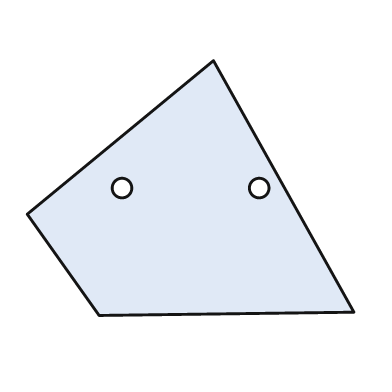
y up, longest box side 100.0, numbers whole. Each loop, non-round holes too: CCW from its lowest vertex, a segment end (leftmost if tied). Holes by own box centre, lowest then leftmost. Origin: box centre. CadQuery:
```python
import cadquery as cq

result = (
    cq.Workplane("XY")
    .moveTo(-28.0, -39.0)
    .lineTo(50.0, -38.0)
    .lineTo(7.0, 39.0)
    .lineTo(-50.0, -8.0)
    .close()
    .moveTo(-21.0, 0.0)
    .circle(3.0)
    .moveTo(21.0, 0.0)
    .circle(3.0)
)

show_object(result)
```